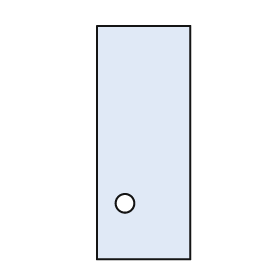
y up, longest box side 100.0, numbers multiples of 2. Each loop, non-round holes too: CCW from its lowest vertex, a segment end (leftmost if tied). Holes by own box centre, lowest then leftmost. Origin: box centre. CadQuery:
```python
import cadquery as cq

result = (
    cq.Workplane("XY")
    .moveTo(-20.0, -50.0)
    .lineTo(20.0, -50.0)
    .lineTo(20.0, 50.0)
    .lineTo(-20.0, 50.0)
    .close()
    .moveTo(-8.0, -26.0)
    .circle(4.0)
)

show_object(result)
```